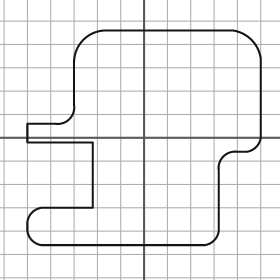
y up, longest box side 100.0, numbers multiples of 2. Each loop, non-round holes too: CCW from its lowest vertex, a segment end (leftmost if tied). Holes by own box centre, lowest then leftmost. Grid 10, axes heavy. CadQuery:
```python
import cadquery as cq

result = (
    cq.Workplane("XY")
    .moveTo(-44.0, -46.0)
    .lineTo(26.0, -46.0)
    .threePointArc((30.0, -44.0), (32.0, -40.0))
    .lineTo(32.0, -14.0)
    .threePointArc((34.0, -8.0), (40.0, -6.0))
    .lineTo(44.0, -6.0)
    .threePointArc((48.0, -4.0), (50.0, 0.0))
    .lineTo(50.0, 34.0)
    .threePointArc((46.0, 42.0), (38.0, 46.0))
    .lineTo(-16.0, 46.0)
    .threePointArc((-26.0, 42.0), (-30.0, 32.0))
    .lineTo(-30.0, 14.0)
    .threePointArc((-32.0, 8.0), (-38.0, 6.0))
    .lineTo(-50.0, 6.0)
    .lineTo(-50.0, -2.0)
    .lineTo(-22.0, -2.0)
    .lineTo(-22.0, -30.0)
    .lineTo(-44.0, -30.0)
    .threePointArc((-48.0, -32.0), (-50.0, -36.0))
    .lineTo(-50.0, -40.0)
    .threePointArc((-48.0, -44.0), (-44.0, -46.0))
    .close()
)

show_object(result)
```